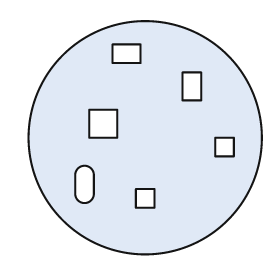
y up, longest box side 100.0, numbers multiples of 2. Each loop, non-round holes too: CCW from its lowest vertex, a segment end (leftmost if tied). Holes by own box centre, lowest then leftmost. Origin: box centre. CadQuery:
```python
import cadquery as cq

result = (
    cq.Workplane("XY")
    .moveTo(0.0, 0.0)
    .circle(50.0)
    .moveTo(-4.0, -30.0)
    .lineTo(4.0, -30.0)
    .lineTo(4.0, -22.0)
    .lineTo(-4.0, -22.0)
    .close()
    .moveTo(-30.0, -24.0)
    .threePointArc((-26.0, -28.0), (-22.0, -24.0))
    .lineTo(-22.0, -16.0)
    .threePointArc((-26.0, -12.0), (-30.0, -16.0))
    .close()
    .moveTo(30.0, -8.0)
    .lineTo(38.0, -8.0)
    .lineTo(38.0, 0.0)
    .lineTo(30.0, 0.0)
    .close()
    .moveTo(-24.0, 0.0)
    .lineTo(-12.0, 0.0)
    .lineTo(-12.0, 12.0)
    .lineTo(-24.0, 12.0)
    .close()
    .moveTo(16.0, 16.0)
    .lineTo(24.0, 16.0)
    .lineTo(24.0, 28.0)
    .lineTo(16.0, 28.0)
    .close()
    .moveTo(-14.0, 32.0)
    .lineTo(-2.0, 32.0)
    .lineTo(-2.0, 40.0)
    .lineTo(-14.0, 40.0)
    .close()
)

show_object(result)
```